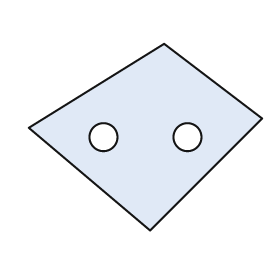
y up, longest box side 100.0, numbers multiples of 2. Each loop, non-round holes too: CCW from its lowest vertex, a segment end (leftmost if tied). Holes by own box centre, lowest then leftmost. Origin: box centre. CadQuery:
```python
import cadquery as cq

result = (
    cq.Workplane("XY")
    .moveTo(2.0, -40.0)
    .lineTo(50.0, 8.0)
    .lineTo(8.0, 40.0)
    .lineTo(-50.0, 4.0)
    .close()
    .moveTo(-18.0, 0.0)
    .circle(6.0)
    .moveTo(18.0, 0.0)
    .circle(6.0)
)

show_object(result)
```